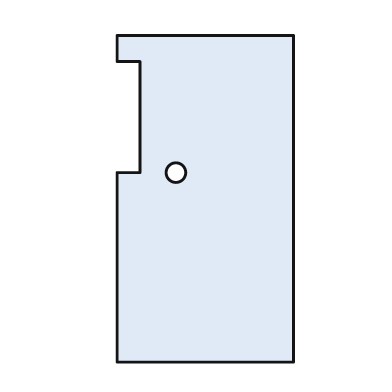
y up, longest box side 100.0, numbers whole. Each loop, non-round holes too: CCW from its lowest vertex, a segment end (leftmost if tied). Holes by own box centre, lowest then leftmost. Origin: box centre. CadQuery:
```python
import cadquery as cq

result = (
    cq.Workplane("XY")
    .moveTo(-27.0, -50.0)
    .lineTo(27.0, -50.0)
    .lineTo(27.0, 50.0)
    .lineTo(-27.0, 50.0)
    .lineTo(-27.0, 42.0)
    .lineTo(-20.0, 42.0)
    .lineTo(-20.0, 8.0)
    .lineTo(-27.0, 8.0)
    .close()
    .moveTo(-9.0, 8.0)
    .circle(3.0)
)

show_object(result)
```